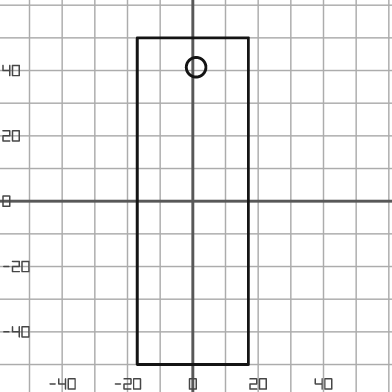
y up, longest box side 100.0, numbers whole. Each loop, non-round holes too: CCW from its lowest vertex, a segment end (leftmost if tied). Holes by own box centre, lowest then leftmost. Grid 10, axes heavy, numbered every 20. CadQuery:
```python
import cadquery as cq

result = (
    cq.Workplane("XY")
    .moveTo(-17.0, -50.0)
    .lineTo(17.0, -50.0)
    .lineTo(17.0, 50.0)
    .lineTo(-17.0, 50.0)
    .close()
    .moveTo(1.0, 41.0)
    .circle(3.0)
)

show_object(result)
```